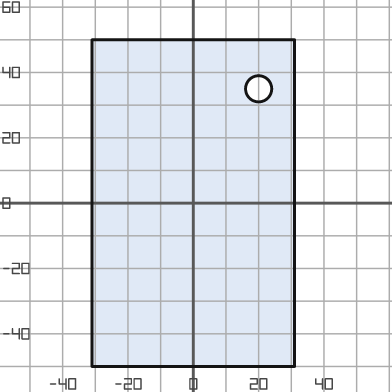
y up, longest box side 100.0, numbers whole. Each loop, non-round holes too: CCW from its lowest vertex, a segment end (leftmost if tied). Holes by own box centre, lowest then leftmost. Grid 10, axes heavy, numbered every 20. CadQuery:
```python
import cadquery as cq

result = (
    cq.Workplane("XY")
    .moveTo(-31.0, -50.0)
    .lineTo(31.0, -50.0)
    .lineTo(31.0, 50.0)
    .lineTo(-31.0, 50.0)
    .close()
    .moveTo(20.0, 35.0)
    .circle(4.0)
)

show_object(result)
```